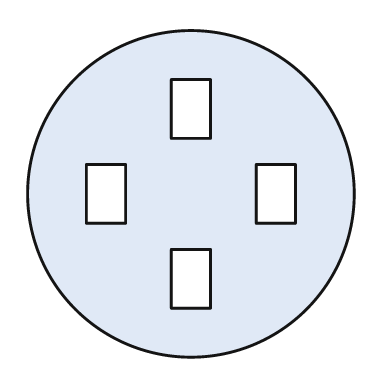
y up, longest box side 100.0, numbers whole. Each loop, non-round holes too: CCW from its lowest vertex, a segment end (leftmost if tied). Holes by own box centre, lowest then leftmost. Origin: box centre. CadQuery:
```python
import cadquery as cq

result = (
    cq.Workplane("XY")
    .moveTo(0.0, 0.0)
    .circle(50.0)
    .moveTo(-6.0, -35.0)
    .lineTo(6.0, -35.0)
    .lineTo(6.0, -17.0)
    .lineTo(-6.0, -17.0)
    .close()
    .moveTo(-32.0, -9.0)
    .lineTo(-20.0, -9.0)
    .lineTo(-20.0, 9.0)
    .lineTo(-32.0, 9.0)
    .close()
    .moveTo(20.0, -9.0)
    .lineTo(32.0, -9.0)
    .lineTo(32.0, 9.0)
    .lineTo(20.0, 9.0)
    .close()
    .moveTo(-6.0, 17.0)
    .lineTo(6.0, 17.0)
    .lineTo(6.0, 35.0)
    .lineTo(-6.0, 35.0)
    .close()
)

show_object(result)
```